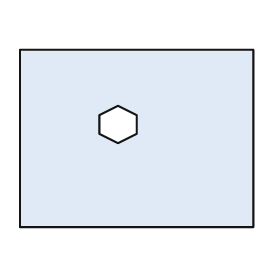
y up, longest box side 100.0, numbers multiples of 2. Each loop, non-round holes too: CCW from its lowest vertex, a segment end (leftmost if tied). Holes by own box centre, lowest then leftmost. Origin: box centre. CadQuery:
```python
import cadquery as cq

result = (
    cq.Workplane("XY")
    .moveTo(-50.0, -38.0)
    .lineTo(50.0, -38.0)
    .lineTo(50.0, 38.0)
    .lineTo(-50.0, 38.0)
    .close()
    .moveTo(-8.0, -2.0)
    .lineTo(0.0, 2.0)
    .lineTo(0.0, 10.0)
    .lineTo(-8.0, 14.0)
    .lineTo(-16.0, 10.0)
    .lineTo(-16.0, 2.0)
    .close()
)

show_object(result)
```